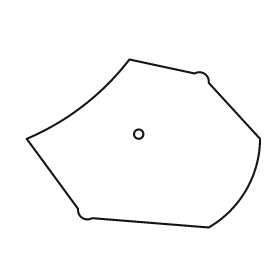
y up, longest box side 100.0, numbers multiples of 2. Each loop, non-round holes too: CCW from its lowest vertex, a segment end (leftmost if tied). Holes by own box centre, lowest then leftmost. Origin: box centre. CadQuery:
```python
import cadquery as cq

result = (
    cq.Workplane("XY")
    .moveTo(28.0, -36.0)
    .threePointArc((44.0, -20.0), (50.0, 2.0))
    .lineTo(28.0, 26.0)
    .threePointArc((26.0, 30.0), (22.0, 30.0))
    .lineTo(-6.0, 36.0)
    .threePointArc((-26.0, 16.0), (-50.0, 2.0))
    .lineTo(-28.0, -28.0)
    .threePointArc((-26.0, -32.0), (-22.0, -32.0))
    .close()
    .moveTo(-2.0, 4.0)
    .circle(2.0)
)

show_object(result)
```